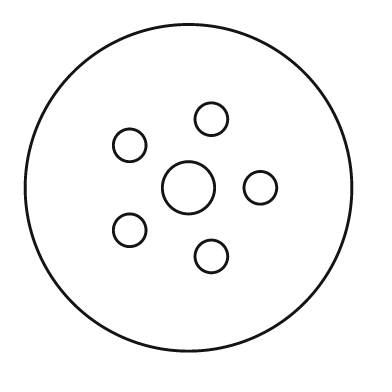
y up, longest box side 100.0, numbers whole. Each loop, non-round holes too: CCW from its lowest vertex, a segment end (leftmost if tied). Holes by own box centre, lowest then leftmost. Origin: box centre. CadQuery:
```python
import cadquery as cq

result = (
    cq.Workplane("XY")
    .moveTo(0.0, 0.0)
    .circle(50.0)
    .moveTo(7.0, -21.0)
    .circle(5.0)
    .moveTo(-18.0, -13.0)
    .circle(5.0)
    .moveTo(0.0, 0.0)
    .circle(8.0)
    .moveTo(22.0, 0.0)
    .circle(5.0)
    .moveTo(-18.0, 13.0)
    .circle(5.0)
    .moveTo(7.0, 21.0)
    .circle(5.0)
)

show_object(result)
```